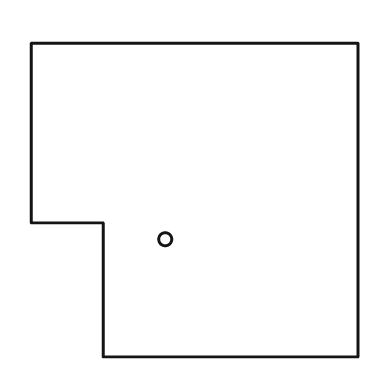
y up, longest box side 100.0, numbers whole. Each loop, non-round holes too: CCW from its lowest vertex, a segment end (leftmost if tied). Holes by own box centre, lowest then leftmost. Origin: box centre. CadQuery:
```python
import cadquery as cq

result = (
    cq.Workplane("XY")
    .moveTo(-28.0, -48.0)
    .lineTo(50.0, -48.0)
    .lineTo(50.0, 48.0)
    .lineTo(-50.0, 48.0)
    .lineTo(-50.0, -7.0)
    .lineTo(-28.0, -7.0)
    .close()
    .moveTo(-9.0, -12.0)
    .circle(2.0)
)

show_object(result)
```